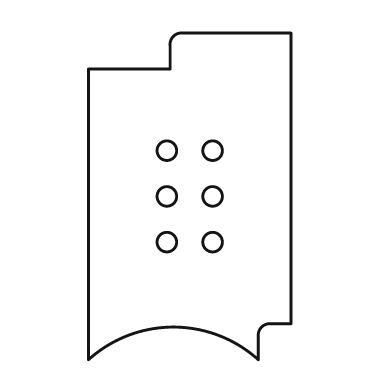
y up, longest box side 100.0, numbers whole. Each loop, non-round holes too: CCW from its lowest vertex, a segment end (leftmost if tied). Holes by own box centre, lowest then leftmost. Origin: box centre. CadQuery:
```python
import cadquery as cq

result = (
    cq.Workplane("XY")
    .moveTo(-31.0, -50.0)
    .threePointArc((-5.0, -40.0), (21.0, -50.0))
    .lineTo(21.0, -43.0)
    .threePointArc((22.0, -40.0), (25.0, -39.0))
    .lineTo(31.0, -39.0)
    .lineTo(31.0, 50.0)
    .lineTo(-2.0, 50.0)
    .threePointArc((-5.0, 49.0), (-6.0, 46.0))
    .lineTo(-6.0, 39.0)
    .lineTo(-31.0, 39.0)
    .close()
    .moveTo(-7.0, -14.0)
    .circle(3.0)
    .moveTo(7.0, -14.0)
    .circle(3.0)
    .moveTo(-7.0, 0.0)
    .circle(3.0)
    .moveTo(7.0, 0.0)
    .circle(3.0)
    .moveTo(-7.0, 14.0)
    .circle(3.0)
    .moveTo(7.0, 14.0)
    .circle(3.0)
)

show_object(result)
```